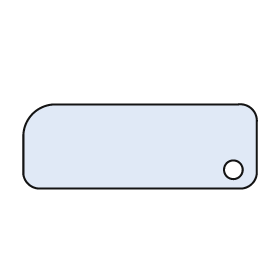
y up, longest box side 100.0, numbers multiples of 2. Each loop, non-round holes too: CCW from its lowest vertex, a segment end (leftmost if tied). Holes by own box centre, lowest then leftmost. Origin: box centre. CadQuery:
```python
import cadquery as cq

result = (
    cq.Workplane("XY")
    .moveTo(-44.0, -18.0)
    .lineTo(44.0, -18.0)
    .threePointArc((48.0, -16.0), (50.0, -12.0))
    .lineTo(50.0, 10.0)
    .threePointArc((48.0, 16.0), (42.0, 18.0))
    .lineTo(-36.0, 18.0)
    .threePointArc((-46.0, 14.0), (-50.0, 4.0))
    .lineTo(-50.0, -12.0)
    .threePointArc((-48.0, -16.0), (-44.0, -18.0))
    .close()
    .moveTo(40.0, -10.0)
    .circle(4.0)
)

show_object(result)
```